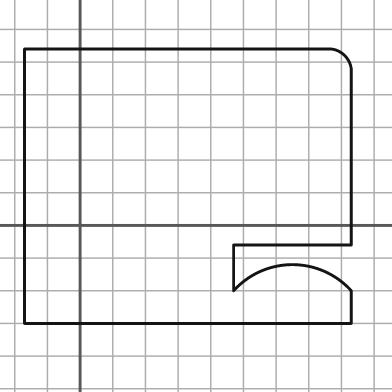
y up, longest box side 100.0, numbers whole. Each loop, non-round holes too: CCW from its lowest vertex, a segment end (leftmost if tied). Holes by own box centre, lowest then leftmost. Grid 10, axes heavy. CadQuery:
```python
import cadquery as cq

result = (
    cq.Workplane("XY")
    .moveTo(-17.0, -30.0)
    .lineTo(83.0, -30.0)
    .lineTo(83.0, -20.0)
    .threePointArc((65.0, -12.0), (47.0, -20.0))
    .lineTo(47.0, -6.0)
    .lineTo(83.0, -6.0)
    .lineTo(83.0, 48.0)
    .threePointArc((81.0, 52.0), (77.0, 54.0))
    .lineTo(-17.0, 54.0)
    .close()
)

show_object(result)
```